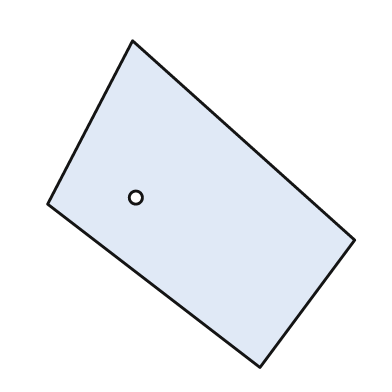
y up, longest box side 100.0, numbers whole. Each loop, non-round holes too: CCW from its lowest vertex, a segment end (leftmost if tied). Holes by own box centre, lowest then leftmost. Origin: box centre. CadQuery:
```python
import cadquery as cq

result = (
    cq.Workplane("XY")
    .moveTo(18.0, -50.0)
    .lineTo(47.0, -11.0)
    .lineTo(-21.0, 50.0)
    .lineTo(-47.0, 0.0)
    .close()
    .moveTo(-20.0, 2.0)
    .circle(2.0)
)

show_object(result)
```